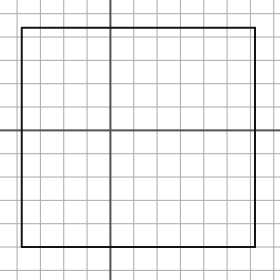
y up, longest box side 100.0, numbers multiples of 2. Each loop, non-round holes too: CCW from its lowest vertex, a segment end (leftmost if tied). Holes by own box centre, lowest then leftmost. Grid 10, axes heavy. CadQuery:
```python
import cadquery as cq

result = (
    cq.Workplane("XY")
    .moveTo(-38.0, -50.0)
    .lineTo(62.0, -50.0)
    .lineTo(62.0, 44.0)
    .lineTo(-38.0, 44.0)
    .close()
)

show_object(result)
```